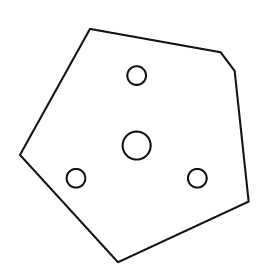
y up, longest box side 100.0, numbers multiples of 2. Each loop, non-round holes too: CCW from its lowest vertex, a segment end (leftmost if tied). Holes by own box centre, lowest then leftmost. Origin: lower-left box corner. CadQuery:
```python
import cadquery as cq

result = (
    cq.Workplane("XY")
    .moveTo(42.0, 0.0)
    .lineTo(98.0, 26.0)
    .lineTo(92.0, 82.0)
    .lineTo(86.0, 90.0)
    .lineTo(30.0, 100.0)
    .lineTo(0.0, 46.0)
    .close()
    .moveTo(24.0, 36.0)
    .circle(4.0)
    .moveTo(76.0, 36.0)
    .circle(4.0)
    .moveTo(50.0, 50.0)
    .circle(6.0)
    .moveTo(50.0, 80.0)
    .circle(4.0)
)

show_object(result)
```